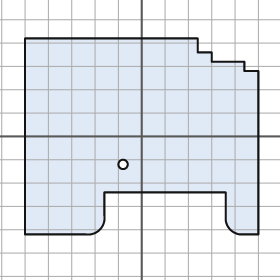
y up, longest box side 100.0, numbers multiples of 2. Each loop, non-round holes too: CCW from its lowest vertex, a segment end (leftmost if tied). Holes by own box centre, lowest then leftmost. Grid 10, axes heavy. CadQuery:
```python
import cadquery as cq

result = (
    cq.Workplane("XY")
    .moveTo(-50.0, -42.0)
    .lineTo(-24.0, -42.0)
    .threePointArc((-18.0, -40.0), (-16.0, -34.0))
    .lineTo(-16.0, -24.0)
    .lineTo(36.0, -24.0)
    .lineTo(36.0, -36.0)
    .threePointArc((38.0, -40.0), (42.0, -42.0))
    .lineTo(50.0, -42.0)
    .lineTo(50.0, 28.0)
    .lineTo(44.0, 28.0)
    .lineTo(44.0, 32.0)
    .lineTo(30.0, 32.0)
    .lineTo(30.0, 36.0)
    .lineTo(24.0, 36.0)
    .lineTo(24.0, 42.0)
    .lineTo(-50.0, 42.0)
    .close()
    .moveTo(-8.0, -12.0)
    .circle(2.0)
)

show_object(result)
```